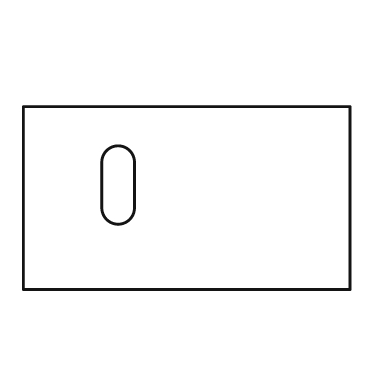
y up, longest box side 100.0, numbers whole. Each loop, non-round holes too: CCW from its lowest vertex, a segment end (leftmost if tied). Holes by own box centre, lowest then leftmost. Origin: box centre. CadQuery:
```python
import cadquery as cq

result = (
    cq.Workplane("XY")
    .moveTo(-50.0, -28.0)
    .lineTo(50.0, -28.0)
    .lineTo(50.0, 28.0)
    .lineTo(-50.0, 28.0)
    .close()
    .moveTo(-26.0, -3.0)
    .threePointArc((-21.0, -8.0), (-16.0, -3.0))
    .lineTo(-16.0, 11.0)
    .threePointArc((-21.0, 16.0), (-26.0, 11.0))
    .close()
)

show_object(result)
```